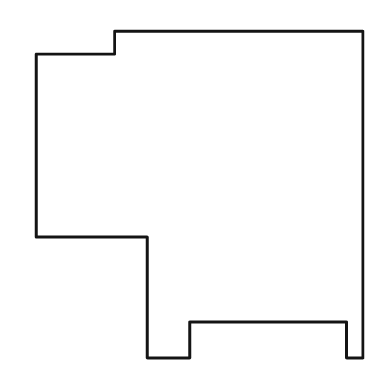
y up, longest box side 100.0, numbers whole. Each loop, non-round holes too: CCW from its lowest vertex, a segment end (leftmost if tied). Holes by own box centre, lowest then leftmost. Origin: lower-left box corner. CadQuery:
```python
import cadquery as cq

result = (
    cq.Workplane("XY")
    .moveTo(34.0, 0.0)
    .lineTo(47.0, 0.0)
    .lineTo(47.0, 11.0)
    .lineTo(95.0, 11.0)
    .lineTo(95.0, 0.0)
    .lineTo(100.0, 0.0)
    .lineTo(100.0, 100.0)
    .lineTo(24.0, 100.0)
    .lineTo(24.0, 93.0)
    .lineTo(0.0, 93.0)
    .lineTo(0.0, 37.0)
    .lineTo(34.0, 37.0)
    .close()
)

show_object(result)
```